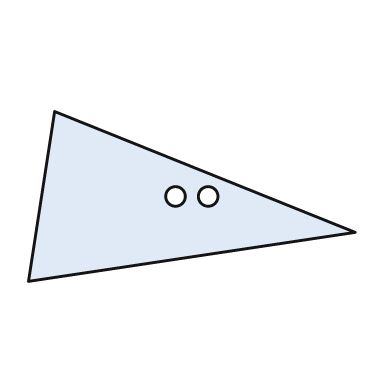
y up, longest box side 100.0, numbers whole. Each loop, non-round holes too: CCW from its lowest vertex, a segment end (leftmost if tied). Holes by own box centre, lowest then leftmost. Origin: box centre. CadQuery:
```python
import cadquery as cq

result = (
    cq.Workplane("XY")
    .moveTo(-50.0, -26.0)
    .lineTo(50.0, -11.0)
    .lineTo(-42.0, 26.0)
    .close()
    .moveTo(-5.0, 0.0)
    .circle(3.0)
    .moveTo(5.0, 0.0)
    .circle(3.0)
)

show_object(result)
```